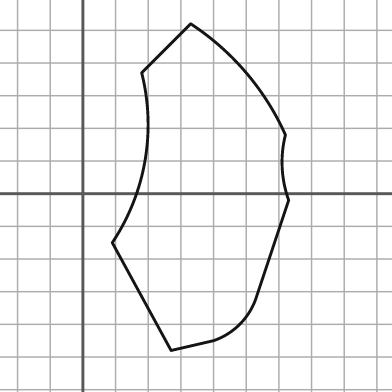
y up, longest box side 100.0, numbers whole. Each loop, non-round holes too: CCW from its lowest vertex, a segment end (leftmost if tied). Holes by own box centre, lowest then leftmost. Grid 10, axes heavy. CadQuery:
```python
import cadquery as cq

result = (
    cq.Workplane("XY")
    .moveTo(27.0, -48.0)
    .lineTo(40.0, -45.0)
    .threePointArc((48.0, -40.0), (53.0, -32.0))
    .lineTo(63.0, -2.0)
    .threePointArc((61.0, 8.0), (62.0, 18.0))
    .threePointArc((50.0, 37.0), (33.0, 52.0))
    .lineTo(18.0, 37.0)
    .threePointArc((19.0, 10.0), (9.0, -15.0))
    .close()
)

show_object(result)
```